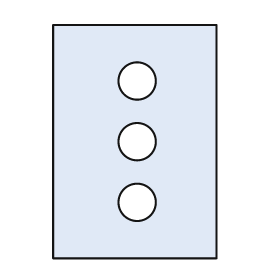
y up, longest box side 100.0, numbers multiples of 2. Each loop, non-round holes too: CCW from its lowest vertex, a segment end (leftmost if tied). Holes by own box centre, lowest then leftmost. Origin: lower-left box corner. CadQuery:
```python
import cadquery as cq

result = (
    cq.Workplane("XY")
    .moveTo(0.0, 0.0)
    .lineTo(70.0, 0.0)
    .lineTo(70.0, 100.0)
    .lineTo(0.0, 100.0)
    .close()
    .moveTo(36.0, 24.0)
    .circle(8.0)
    .moveTo(36.0, 50.0)
    .circle(8.0)
    .moveTo(36.0, 76.0)
    .circle(8.0)
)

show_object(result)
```